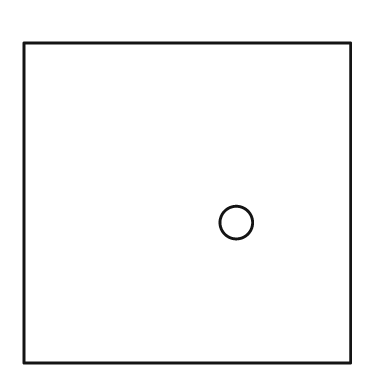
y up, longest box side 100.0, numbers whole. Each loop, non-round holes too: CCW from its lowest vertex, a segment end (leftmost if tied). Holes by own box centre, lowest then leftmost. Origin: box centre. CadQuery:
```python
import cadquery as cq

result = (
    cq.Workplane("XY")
    .moveTo(-50.0, -49.0)
    .lineTo(50.0, -49.0)
    .lineTo(50.0, 49.0)
    .lineTo(-50.0, 49.0)
    .close()
    .moveTo(15.0, -6.0)
    .circle(5.0)
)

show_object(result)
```